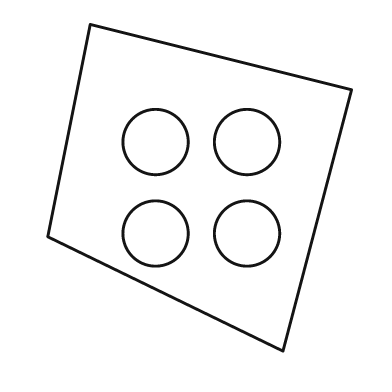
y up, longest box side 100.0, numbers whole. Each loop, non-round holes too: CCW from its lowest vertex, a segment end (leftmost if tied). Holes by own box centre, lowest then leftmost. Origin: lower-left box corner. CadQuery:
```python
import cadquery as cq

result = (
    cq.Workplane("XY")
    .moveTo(72.0, 0.0)
    .lineTo(93.0, 80.0)
    .lineTo(13.0, 100.0)
    .lineTo(0.0, 35.0)
    .close()
    .moveTo(33.0, 36.0)
    .circle(10.0)
    .moveTo(61.0, 36.0)
    .circle(10.0)
    .moveTo(33.0, 64.0)
    .circle(10.0)
    .moveTo(61.0, 64.0)
    .circle(10.0)
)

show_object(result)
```